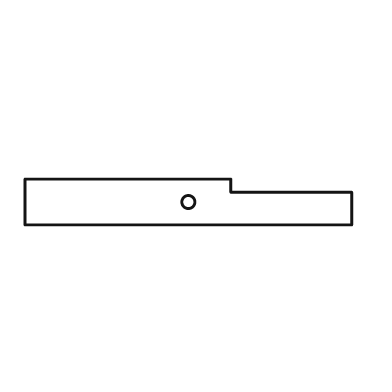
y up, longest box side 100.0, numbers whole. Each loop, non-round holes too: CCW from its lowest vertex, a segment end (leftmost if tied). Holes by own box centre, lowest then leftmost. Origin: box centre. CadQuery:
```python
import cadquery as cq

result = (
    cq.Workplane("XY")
    .moveTo(-50.0, -7.0)
    .lineTo(50.0, -7.0)
    .lineTo(50.0, 3.0)
    .lineTo(13.0, 3.0)
    .lineTo(13.0, 7.0)
    .lineTo(-50.0, 7.0)
    .close()
    .moveTo(0.0, 0.0)
    .circle(2.0)
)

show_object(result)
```